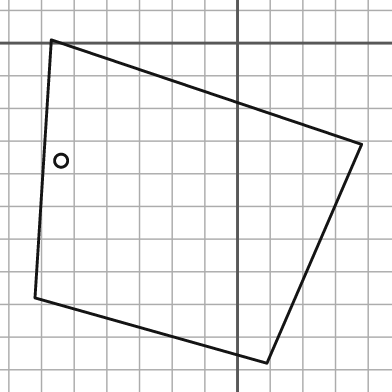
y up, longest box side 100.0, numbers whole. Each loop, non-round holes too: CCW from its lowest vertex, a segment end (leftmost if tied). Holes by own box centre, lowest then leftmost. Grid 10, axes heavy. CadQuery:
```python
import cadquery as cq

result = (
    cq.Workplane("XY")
    .moveTo(9.0, -98.0)
    .lineTo(38.0, -31.0)
    .lineTo(-57.0, 1.0)
    .lineTo(-62.0, -78.0)
    .close()
    .moveTo(-54.0, -36.0)
    .circle(2.0)
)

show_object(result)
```